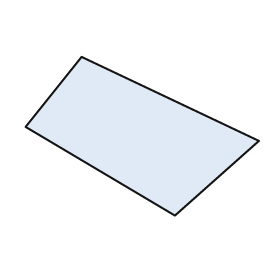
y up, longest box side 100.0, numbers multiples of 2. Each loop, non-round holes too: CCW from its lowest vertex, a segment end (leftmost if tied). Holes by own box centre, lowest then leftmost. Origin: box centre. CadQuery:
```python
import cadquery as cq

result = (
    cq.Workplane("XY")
    .moveTo(14.0, -34.0)
    .lineTo(50.0, -2.0)
    .lineTo(-26.0, 34.0)
    .lineTo(-50.0, 4.0)
    .close()
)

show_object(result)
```